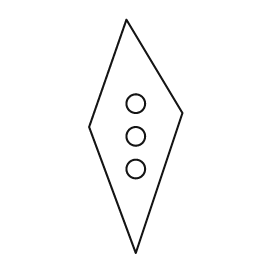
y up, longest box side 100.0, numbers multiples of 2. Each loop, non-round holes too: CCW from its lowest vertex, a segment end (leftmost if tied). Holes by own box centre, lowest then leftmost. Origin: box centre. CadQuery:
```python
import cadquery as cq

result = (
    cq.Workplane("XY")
    .moveTo(0.0, -50.0)
    .lineTo(20.0, 10.0)
    .lineTo(-4.0, 50.0)
    .lineTo(-20.0, 4.0)
    .close()
    .moveTo(0.0, -14.0)
    .circle(4.0)
    .moveTo(0.0, 0.0)
    .circle(4.0)
    .moveTo(0.0, 14.0)
    .circle(4.0)
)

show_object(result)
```